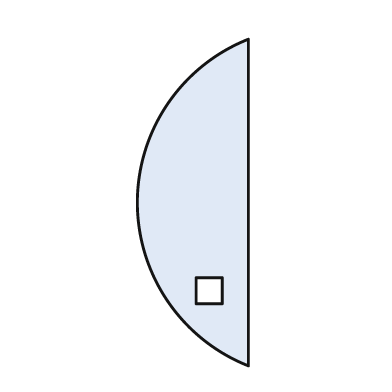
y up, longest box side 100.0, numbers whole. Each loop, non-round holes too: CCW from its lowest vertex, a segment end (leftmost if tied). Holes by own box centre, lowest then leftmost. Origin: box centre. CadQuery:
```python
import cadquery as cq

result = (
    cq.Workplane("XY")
    .moveTo(17.0, -50.0)
    .lineTo(17.0, 50.0)
    .threePointArc((-17.0, 0.0), (17.0, -50.0))
    .close()
    .moveTo(1.0, -31.0)
    .lineTo(9.0, -31.0)
    .lineTo(9.0, -23.0)
    .lineTo(1.0, -23.0)
    .close()
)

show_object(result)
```